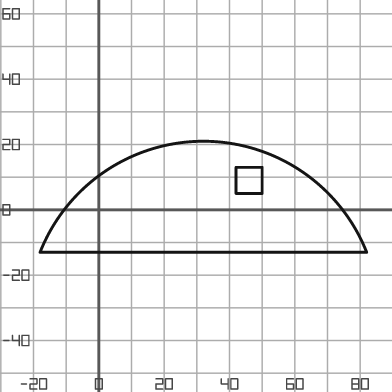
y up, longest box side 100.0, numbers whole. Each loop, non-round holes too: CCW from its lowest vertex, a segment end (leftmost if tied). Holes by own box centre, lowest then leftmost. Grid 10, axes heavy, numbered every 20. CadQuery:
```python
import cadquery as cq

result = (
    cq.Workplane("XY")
    .moveTo(-18.0, -13.0)
    .lineTo(82.0, -13.0)
    .threePointArc((32.0, 21.0), (-18.0, -13.0))
    .close()
    .moveTo(42.0, 5.0)
    .lineTo(50.0, 5.0)
    .lineTo(50.0, 13.0)
    .lineTo(42.0, 13.0)
    .close()
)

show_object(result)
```